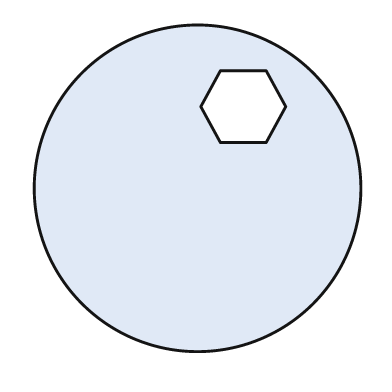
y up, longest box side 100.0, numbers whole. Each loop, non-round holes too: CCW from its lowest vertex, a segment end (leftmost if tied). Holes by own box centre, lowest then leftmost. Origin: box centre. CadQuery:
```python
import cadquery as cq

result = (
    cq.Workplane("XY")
    .moveTo(0.0, 0.0)
    .circle(50.0)
    .moveTo(7.0, 14.0)
    .lineTo(21.0, 14.0)
    .lineTo(27.0, 25.0)
    .lineTo(21.0, 36.0)
    .lineTo(7.0, 36.0)
    .lineTo(1.0, 25.0)
    .close()
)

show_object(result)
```